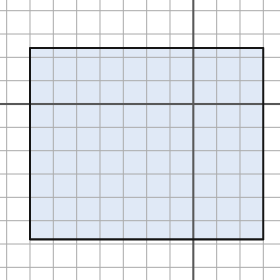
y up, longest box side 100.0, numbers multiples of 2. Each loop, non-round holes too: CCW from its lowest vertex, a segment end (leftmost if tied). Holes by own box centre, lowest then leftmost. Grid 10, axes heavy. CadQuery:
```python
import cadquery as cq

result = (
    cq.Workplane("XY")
    .moveTo(-70.0, -58.0)
    .lineTo(30.0, -58.0)
    .lineTo(30.0, 24.0)
    .lineTo(-70.0, 24.0)
    .close()
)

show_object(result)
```